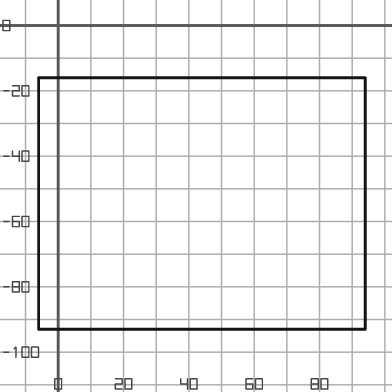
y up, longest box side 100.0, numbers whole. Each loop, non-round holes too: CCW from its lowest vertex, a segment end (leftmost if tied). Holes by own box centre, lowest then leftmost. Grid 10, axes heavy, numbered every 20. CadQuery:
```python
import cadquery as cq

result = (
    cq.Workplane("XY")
    .moveTo(-6.0, -93.0)
    .lineTo(94.0, -93.0)
    .lineTo(94.0, -16.0)
    .lineTo(-6.0, -16.0)
    .close()
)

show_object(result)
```